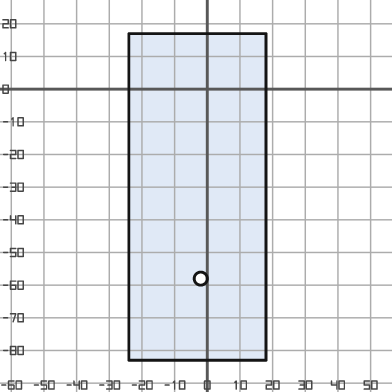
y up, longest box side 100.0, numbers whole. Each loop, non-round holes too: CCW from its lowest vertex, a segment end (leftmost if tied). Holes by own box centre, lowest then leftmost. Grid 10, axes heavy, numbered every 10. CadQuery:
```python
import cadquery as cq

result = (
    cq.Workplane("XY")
    .moveTo(-24.0, -83.0)
    .lineTo(18.0, -83.0)
    .lineTo(18.0, 17.0)
    .lineTo(-24.0, 17.0)
    .close()
    .moveTo(-2.0, -58.0)
    .circle(2.0)
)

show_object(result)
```